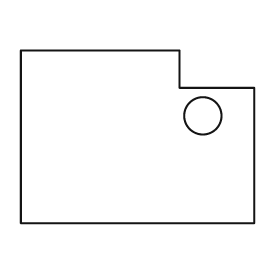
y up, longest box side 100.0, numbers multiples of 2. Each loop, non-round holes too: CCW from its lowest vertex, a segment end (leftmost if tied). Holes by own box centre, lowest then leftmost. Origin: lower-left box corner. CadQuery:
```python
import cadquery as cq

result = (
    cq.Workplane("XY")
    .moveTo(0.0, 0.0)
    .lineTo(100.0, 0.0)
    .lineTo(100.0, 58.0)
    .lineTo(68.0, 58.0)
    .lineTo(68.0, 74.0)
    .lineTo(0.0, 74.0)
    .close()
    .moveTo(78.0, 46.0)
    .circle(8.0)
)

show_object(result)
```